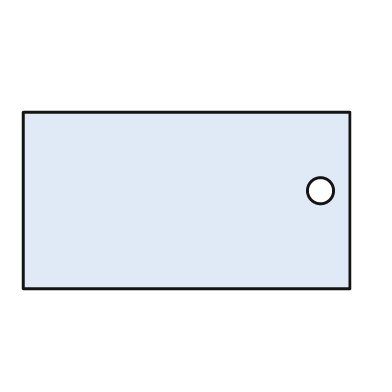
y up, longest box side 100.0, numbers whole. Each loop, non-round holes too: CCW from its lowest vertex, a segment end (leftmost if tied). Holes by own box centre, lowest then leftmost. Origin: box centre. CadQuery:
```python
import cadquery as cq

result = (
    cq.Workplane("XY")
    .moveTo(-50.0, -27.0)
    .lineTo(50.0, -27.0)
    .lineTo(50.0, 27.0)
    .lineTo(-50.0, 27.0)
    .close()
    .moveTo(41.0, 3.0)
    .circle(4.0)
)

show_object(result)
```